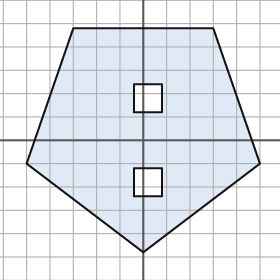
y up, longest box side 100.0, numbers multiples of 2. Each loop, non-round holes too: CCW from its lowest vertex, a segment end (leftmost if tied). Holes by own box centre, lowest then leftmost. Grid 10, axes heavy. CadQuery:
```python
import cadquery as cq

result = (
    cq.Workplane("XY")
    .moveTo(0.0, -48.0)
    .lineTo(50.0, -10.0)
    .lineTo(30.0, 48.0)
    .lineTo(-30.0, 48.0)
    .lineTo(-50.0, -10.0)
    .close()
    .moveTo(-4.0, -24.0)
    .lineTo(8.0, -24.0)
    .lineTo(8.0, -12.0)
    .lineTo(-4.0, -12.0)
    .close()
    .moveTo(-4.0, 12.0)
    .lineTo(8.0, 12.0)
    .lineTo(8.0, 24.0)
    .lineTo(-4.0, 24.0)
    .close()
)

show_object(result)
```